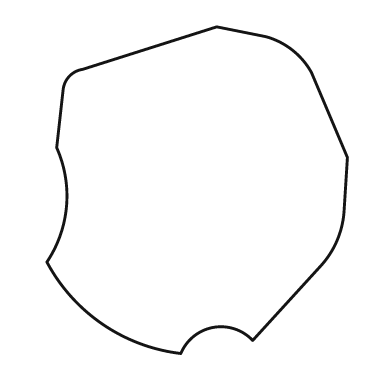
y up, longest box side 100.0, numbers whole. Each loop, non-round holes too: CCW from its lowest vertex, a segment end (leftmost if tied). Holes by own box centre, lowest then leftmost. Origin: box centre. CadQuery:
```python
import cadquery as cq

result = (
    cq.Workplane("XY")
    .moveTo(-5.0, -50.0)
    .threePointArc((5.0, -42.0), (17.0, -46.0))
    .lineTo(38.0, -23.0)
    .threePointArc((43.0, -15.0), (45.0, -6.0))
    .lineTo(46.0, 10.0)
    .lineTo(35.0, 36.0)
    .threePointArc((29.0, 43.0), (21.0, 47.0))
    .lineTo(6.0, 50.0)
    .lineTo(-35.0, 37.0)
    .threePointArc((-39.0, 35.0), (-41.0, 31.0))
    .lineTo(-43.0, 13.0)
    .threePointArc((-40.0, -5.0), (-46.0, -22.0))
    .threePointArc((-29.0, -41.0), (-5.0, -50.0))
    .close()
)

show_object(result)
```